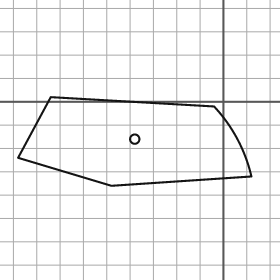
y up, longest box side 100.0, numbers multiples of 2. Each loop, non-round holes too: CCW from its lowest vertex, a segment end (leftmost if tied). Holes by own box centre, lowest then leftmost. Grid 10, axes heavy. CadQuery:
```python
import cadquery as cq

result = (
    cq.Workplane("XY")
    .moveTo(-48.0, -36.0)
    .lineTo(12.0, -32.0)
    .threePointArc((6.0, -16.0), (-4.0, -2.0))
    .lineTo(-74.0, 2.0)
    .lineTo(-88.0, -24.0)
    .close()
    .moveTo(-38.0, -16.0)
    .circle(2.0)
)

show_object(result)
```